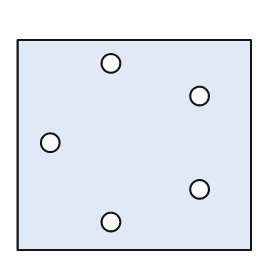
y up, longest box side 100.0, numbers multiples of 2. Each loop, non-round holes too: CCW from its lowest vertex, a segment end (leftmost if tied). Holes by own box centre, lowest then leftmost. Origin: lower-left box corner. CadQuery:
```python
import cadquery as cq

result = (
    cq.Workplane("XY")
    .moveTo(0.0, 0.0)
    .lineTo(100.0, 0.0)
    .lineTo(100.0, 90.0)
    .lineTo(0.0, 90.0)
    .close()
    .moveTo(40.0, 12.0)
    .circle(4.0)
    .moveTo(78.0, 26.0)
    .circle(4.0)
    .moveTo(14.0, 46.0)
    .circle(4.0)
    .moveTo(78.0, 66.0)
    .circle(4.0)
    .moveTo(40.0, 80.0)
    .circle(4.0)
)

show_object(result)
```